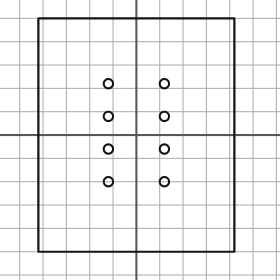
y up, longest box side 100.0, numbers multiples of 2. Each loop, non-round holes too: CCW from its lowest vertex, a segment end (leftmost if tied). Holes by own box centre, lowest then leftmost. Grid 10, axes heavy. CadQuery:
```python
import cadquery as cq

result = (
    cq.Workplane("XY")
    .moveTo(-42.0, -50.0)
    .lineTo(42.0, -50.0)
    .lineTo(42.0, 50.0)
    .lineTo(-42.0, 50.0)
    .close()
    .moveTo(-12.0, -20.0)
    .circle(2.0)
    .moveTo(12.0, -20.0)
    .circle(2.0)
    .moveTo(-12.0, -6.0)
    .circle(2.0)
    .moveTo(12.0, -6.0)
    .circle(2.0)
    .moveTo(-12.0, 8.0)
    .circle(2.0)
    .moveTo(12.0, 8.0)
    .circle(2.0)
    .moveTo(-12.0, 22.0)
    .circle(2.0)
    .moveTo(12.0, 22.0)
    .circle(2.0)
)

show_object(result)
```